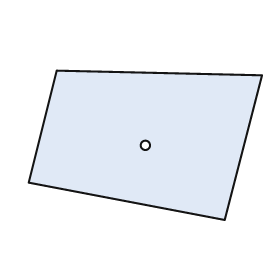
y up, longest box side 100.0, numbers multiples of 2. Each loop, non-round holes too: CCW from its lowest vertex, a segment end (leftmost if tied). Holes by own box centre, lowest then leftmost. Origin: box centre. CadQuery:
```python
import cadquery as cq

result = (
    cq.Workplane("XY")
    .moveTo(34.0, -32.0)
    .lineTo(50.0, 30.0)
    .lineTo(-38.0, 32.0)
    .lineTo(-50.0, -16.0)
    .close()
    .moveTo(0.0, 0.0)
    .circle(2.0)
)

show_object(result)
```